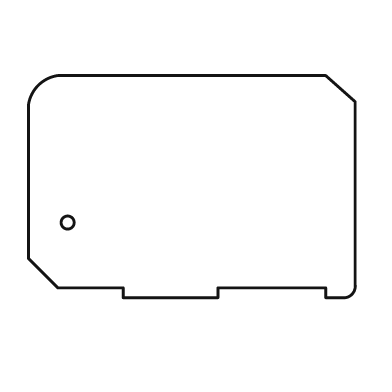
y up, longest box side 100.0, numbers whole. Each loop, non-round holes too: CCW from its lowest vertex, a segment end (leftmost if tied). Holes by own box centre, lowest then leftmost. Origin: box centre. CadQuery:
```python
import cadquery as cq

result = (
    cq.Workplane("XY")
    .moveTo(-21.0, -34.0)
    .lineTo(8.0, -34.0)
    .lineTo(8.0, -31.0)
    .lineTo(41.0, -31.0)
    .lineTo(41.0, -34.0)
    .lineTo(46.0, -34.0)
    .threePointArc((49.0, -33.0), (50.0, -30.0))
    .lineTo(50.0, 26.0)
    .lineTo(41.0, 34.0)
    .lineTo(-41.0, 34.0)
    .threePointArc((-47.0, 31.0), (-50.0, 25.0))
    .lineTo(-50.0, -22.0)
    .lineTo(-41.0, -31.0)
    .lineTo(-21.0, -31.0)
    .close()
    .moveTo(-38.0, -11.0)
    .circle(2.0)
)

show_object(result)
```